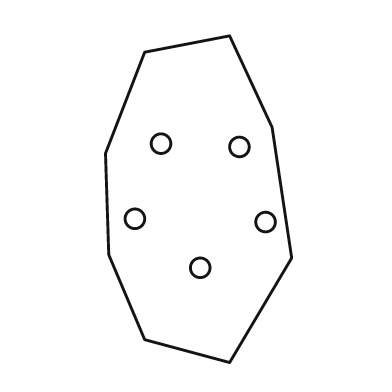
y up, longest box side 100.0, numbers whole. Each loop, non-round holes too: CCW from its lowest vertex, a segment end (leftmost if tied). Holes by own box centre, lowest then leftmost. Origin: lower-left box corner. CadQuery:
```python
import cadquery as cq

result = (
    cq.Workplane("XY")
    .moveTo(38.0, 0.0)
    .lineTo(57.0, 32.0)
    .lineTo(51.0, 72.0)
    .lineTo(38.0, 100.0)
    .lineTo(12.0, 95.0)
    .lineTo(0.0, 64.0)
    .lineTo(1.0, 33.0)
    .lineTo(12.0, 7.0)
    .close()
    .moveTo(29.0, 29.0)
    .circle(3.0)
    .moveTo(49.0, 43.0)
    .circle(3.0)
    .moveTo(9.0, 44.0)
    .circle(3.0)
    .moveTo(41.0, 66.0)
    .circle(3.0)
    .moveTo(17.0, 67.0)
    .circle(3.0)
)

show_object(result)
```